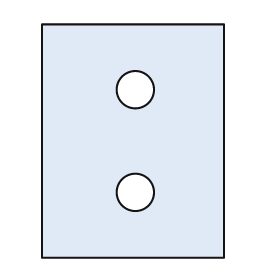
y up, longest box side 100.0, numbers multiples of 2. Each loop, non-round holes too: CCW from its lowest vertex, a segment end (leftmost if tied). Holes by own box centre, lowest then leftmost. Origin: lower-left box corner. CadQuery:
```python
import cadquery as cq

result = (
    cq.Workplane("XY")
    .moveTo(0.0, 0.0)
    .lineTo(78.0, 0.0)
    .lineTo(78.0, 100.0)
    .lineTo(0.0, 100.0)
    .close()
    .moveTo(40.0, 28.0)
    .circle(8.0)
    .moveTo(40.0, 72.0)
    .circle(8.0)
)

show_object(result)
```